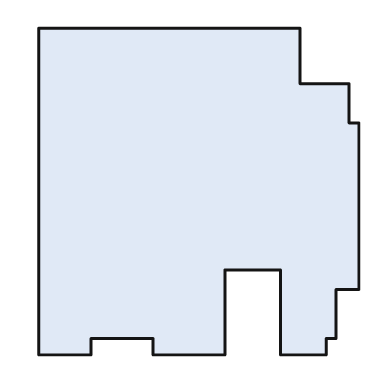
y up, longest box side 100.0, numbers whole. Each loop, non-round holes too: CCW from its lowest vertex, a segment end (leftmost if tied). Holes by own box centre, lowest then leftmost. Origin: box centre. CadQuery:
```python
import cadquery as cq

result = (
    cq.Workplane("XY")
    .moveTo(-49.0, -50.0)
    .lineTo(-33.0, -50.0)
    .lineTo(-33.0, -45.0)
    .lineTo(-14.0, -45.0)
    .lineTo(-14.0, -50.0)
    .lineTo(8.0, -50.0)
    .lineTo(8.0, -24.0)
    .lineTo(25.0, -24.0)
    .lineTo(25.0, -50.0)
    .lineTo(39.0, -50.0)
    .lineTo(39.0, -45.0)
    .lineTo(42.0, -45.0)
    .lineTo(42.0, -30.0)
    .lineTo(49.0, -30.0)
    .lineTo(49.0, 21.0)
    .lineTo(46.0, 21.0)
    .lineTo(46.0, 33.0)
    .lineTo(31.0, 33.0)
    .lineTo(31.0, 50.0)
    .lineTo(-49.0, 50.0)
    .close()
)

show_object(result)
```